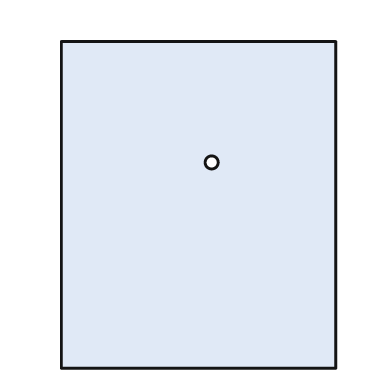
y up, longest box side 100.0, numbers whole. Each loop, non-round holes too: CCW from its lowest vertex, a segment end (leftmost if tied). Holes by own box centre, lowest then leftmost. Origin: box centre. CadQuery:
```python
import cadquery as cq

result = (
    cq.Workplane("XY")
    .moveTo(-42.0, -50.0)
    .lineTo(42.0, -50.0)
    .lineTo(42.0, 50.0)
    .lineTo(-42.0, 50.0)
    .close()
    .moveTo(4.0, 13.0)
    .circle(2.0)
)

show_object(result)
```